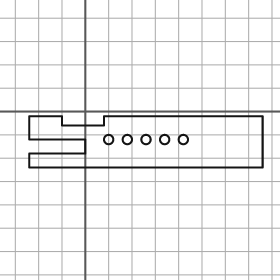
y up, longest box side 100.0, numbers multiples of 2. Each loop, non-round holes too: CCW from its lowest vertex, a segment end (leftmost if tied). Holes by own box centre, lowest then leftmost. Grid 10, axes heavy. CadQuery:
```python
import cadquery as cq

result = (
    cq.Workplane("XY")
    .moveTo(-24.0, -24.0)
    .lineTo(76.0, -24.0)
    .lineTo(76.0, -2.0)
    .lineTo(8.0, -2.0)
    .lineTo(8.0, -6.0)
    .lineTo(-10.0, -6.0)
    .lineTo(-10.0, -2.0)
    .lineTo(-24.0, -2.0)
    .lineTo(-24.0, -12.0)
    .lineTo(0.0, -12.0)
    .lineTo(0.0, -18.0)
    .lineTo(-24.0, -18.0)
    .close()
    .moveTo(10.0, -12.0)
    .circle(2.0)
    .moveTo(18.0, -12.0)
    .circle(2.0)
    .moveTo(26.0, -12.0)
    .circle(2.0)
    .moveTo(34.0, -12.0)
    .circle(2.0)
    .moveTo(42.0, -12.0)
    .circle(2.0)
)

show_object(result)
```